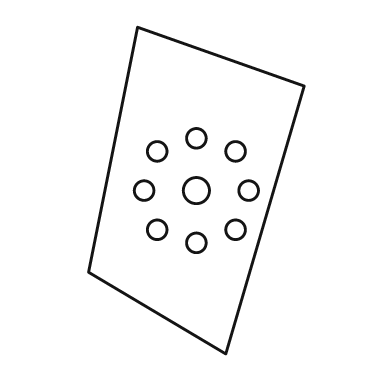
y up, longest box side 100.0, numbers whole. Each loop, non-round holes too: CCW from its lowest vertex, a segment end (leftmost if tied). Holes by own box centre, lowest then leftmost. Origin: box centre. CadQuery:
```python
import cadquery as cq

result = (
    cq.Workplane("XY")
    .moveTo(9.0, -50.0)
    .lineTo(33.0, 32.0)
    .lineTo(-18.0, 50.0)
    .lineTo(-33.0, -25.0)
    .close()
    .moveTo(0.0, -16.0)
    .circle(3.0)
    .moveTo(-12.0, -12.0)
    .circle(3.0)
    .moveTo(12.0, -12.0)
    .circle(3.0)
    .moveTo(-16.0, 0.0)
    .circle(3.0)
    .moveTo(0.0, 0.0)
    .circle(4.0)
    .moveTo(16.0, 0.0)
    .circle(3.0)
    .moveTo(-12.0, 12.0)
    .circle(3.0)
    .moveTo(12.0, 12.0)
    .circle(3.0)
    .moveTo(0.0, 16.0)
    .circle(3.0)
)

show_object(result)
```